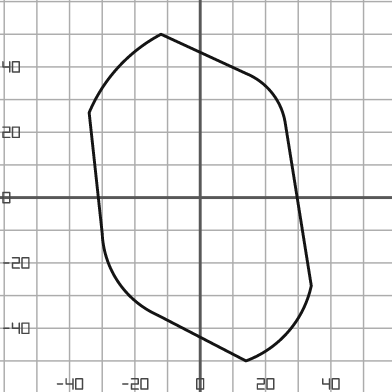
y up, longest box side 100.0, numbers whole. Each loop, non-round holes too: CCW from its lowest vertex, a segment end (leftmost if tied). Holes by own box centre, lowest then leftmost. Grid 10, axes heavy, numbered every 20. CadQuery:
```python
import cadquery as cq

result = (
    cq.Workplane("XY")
    .moveTo(14.0, -50.0)
    .threePointArc((27.0, -41.0), (34.0, -27.0))
    .lineTo(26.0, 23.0)
    .threePointArc((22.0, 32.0), (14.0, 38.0))
    .lineTo(-12.0, 50.0)
    .threePointArc((-25.0, 40.0), (-34.0, 26.0))
    .lineTo(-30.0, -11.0)
    .threePointArc((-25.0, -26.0), (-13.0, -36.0))
    .close()
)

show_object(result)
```